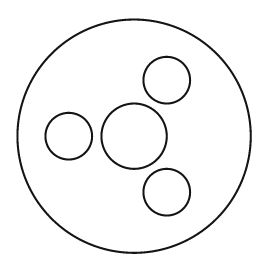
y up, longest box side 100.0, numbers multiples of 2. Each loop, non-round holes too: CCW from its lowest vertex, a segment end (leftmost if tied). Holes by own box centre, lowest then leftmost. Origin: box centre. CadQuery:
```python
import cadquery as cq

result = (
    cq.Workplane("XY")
    .moveTo(0.0, 0.0)
    .circle(50.0)
    .moveTo(14.0, -24.0)
    .circle(10.0)
    .moveTo(-28.0, 0.0)
    .circle(10.0)
    .moveTo(0.0, 0.0)
    .circle(14.0)
    .moveTo(14.0, 24.0)
    .circle(10.0)
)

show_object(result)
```